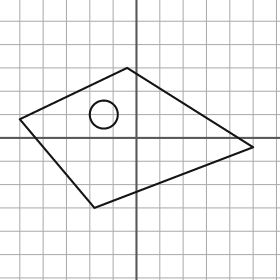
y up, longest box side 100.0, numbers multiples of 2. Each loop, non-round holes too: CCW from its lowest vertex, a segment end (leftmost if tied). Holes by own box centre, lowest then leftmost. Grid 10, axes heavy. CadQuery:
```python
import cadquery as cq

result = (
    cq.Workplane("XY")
    .moveTo(-18.0, -30.0)
    .lineTo(50.0, -4.0)
    .lineTo(-4.0, 30.0)
    .lineTo(-50.0, 8.0)
    .close()
    .moveTo(-14.0, 10.0)
    .circle(6.0)
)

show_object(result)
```